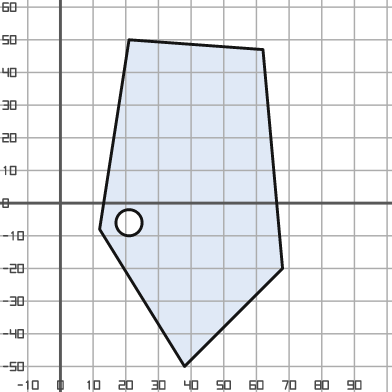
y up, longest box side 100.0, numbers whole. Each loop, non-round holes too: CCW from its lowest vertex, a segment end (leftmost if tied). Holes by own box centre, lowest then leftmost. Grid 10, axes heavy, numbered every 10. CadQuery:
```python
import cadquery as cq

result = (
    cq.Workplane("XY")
    .moveTo(38.0, -50.0)
    .lineTo(68.0, -20.0)
    .lineTo(62.0, 47.0)
    .lineTo(21.0, 50.0)
    .lineTo(12.0, -8.0)
    .close()
    .moveTo(21.0, -6.0)
    .circle(4.0)
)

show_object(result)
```